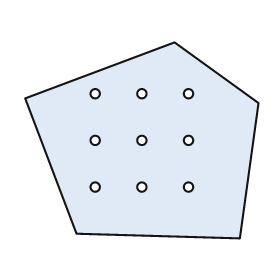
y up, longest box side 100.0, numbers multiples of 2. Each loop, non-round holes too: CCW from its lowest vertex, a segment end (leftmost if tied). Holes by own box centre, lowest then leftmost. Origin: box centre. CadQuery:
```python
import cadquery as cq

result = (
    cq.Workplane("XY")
    .moveTo(42.0, -42.0)
    .lineTo(50.0, 16.0)
    .lineTo(14.0, 42.0)
    .lineTo(-50.0, 18.0)
    .lineTo(-28.0, -40.0)
    .close()
    .moveTo(-20.0, -20.0)
    .circle(2.0)
    .moveTo(0.0, -20.0)
    .circle(2.0)
    .moveTo(20.0, -20.0)
    .circle(2.0)
    .moveTo(-20.0, 0.0)
    .circle(2.0)
    .moveTo(0.0, 0.0)
    .circle(2.0)
    .moveTo(20.0, 0.0)
    .circle(2.0)
    .moveTo(-20.0, 20.0)
    .circle(2.0)
    .moveTo(0.0, 20.0)
    .circle(2.0)
    .moveTo(20.0, 20.0)
    .circle(2.0)
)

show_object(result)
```